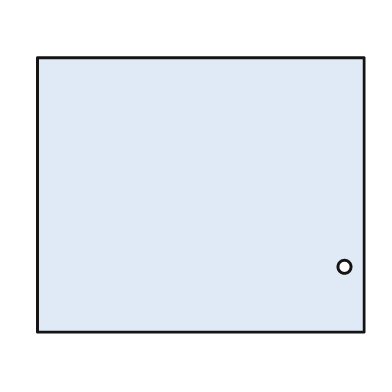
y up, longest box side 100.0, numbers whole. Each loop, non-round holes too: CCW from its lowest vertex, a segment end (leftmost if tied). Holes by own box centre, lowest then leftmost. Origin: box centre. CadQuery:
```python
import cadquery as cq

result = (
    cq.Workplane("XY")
    .moveTo(-50.0, -42.0)
    .lineTo(50.0, -42.0)
    .lineTo(50.0, 42.0)
    .lineTo(-50.0, 42.0)
    .close()
    .moveTo(44.0, -22.0)
    .circle(2.0)
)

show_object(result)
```